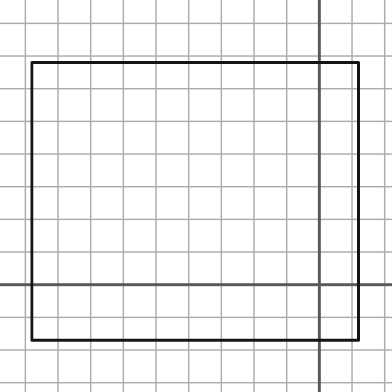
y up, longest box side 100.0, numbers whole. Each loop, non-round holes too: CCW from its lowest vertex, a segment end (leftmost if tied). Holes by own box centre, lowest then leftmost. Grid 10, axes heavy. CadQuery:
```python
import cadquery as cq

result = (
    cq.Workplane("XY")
    .moveTo(-88.0, -17.0)
    .lineTo(12.0, -17.0)
    .lineTo(12.0, 68.0)
    .lineTo(-88.0, 68.0)
    .close()
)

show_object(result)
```